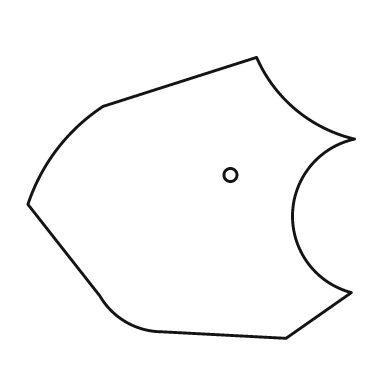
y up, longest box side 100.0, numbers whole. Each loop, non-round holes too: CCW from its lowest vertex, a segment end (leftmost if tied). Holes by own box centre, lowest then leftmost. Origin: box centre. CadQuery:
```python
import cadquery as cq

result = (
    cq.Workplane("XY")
    .moveTo(29.0, -43.0)
    .lineTo(49.0, -29.0)
    .threePointArc((31.0, -5.0), (50.0, 18.0))
    .threePointArc((32.0, 27.0), (20.0, 43.0))
    .lineTo(-27.0, 28.0)
    .threePointArc((-41.0, 15.0), (-50.0, -2.0))
    .lineTo(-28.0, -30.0)
    .threePointArc((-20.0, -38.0), (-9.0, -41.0))
    .close()
    .moveTo(12.0, 7.0)
    .circle(2.0)
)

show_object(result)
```